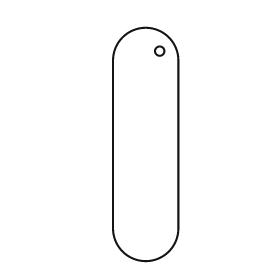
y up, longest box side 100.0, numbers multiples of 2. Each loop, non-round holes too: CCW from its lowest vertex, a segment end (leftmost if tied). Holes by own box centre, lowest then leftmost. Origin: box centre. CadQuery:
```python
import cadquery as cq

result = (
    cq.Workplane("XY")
    .moveTo(-14.0, -36.0)
    .threePointArc((0.0, -50.0), (14.0, -36.0))
    .lineTo(14.0, 36.0)
    .threePointArc((0.0, 50.0), (-14.0, 36.0))
    .close()
    .moveTo(6.0, 40.0)
    .circle(2.0)
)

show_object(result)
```